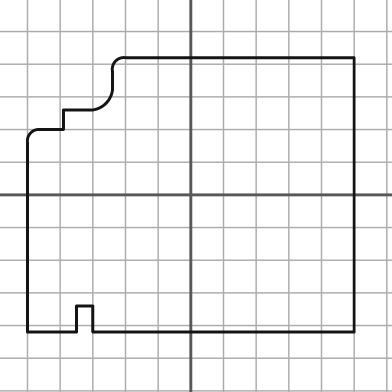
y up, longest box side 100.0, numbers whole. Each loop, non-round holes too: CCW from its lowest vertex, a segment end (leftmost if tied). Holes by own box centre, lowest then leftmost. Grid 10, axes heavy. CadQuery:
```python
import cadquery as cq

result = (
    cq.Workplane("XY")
    .moveTo(-50.0, -42.0)
    .lineTo(-35.0, -42.0)
    .lineTo(-35.0, -34.0)
    .lineTo(-30.0, -34.0)
    .lineTo(-30.0, -42.0)
    .lineTo(50.0, -42.0)
    .lineTo(50.0, 42.0)
    .lineTo(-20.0, 42.0)
    .threePointArc((-23.0, 41.0), (-24.0, 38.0))
    .lineTo(-24.0, 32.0)
    .threePointArc((-26.0, 28.0), (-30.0, 26.0))
    .lineTo(-39.0, 26.0)
    .lineTo(-39.0, 20.0)
    .lineTo(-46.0, 20.0)
    .threePointArc((-49.0, 19.0), (-50.0, 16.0))
    .close()
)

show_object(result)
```